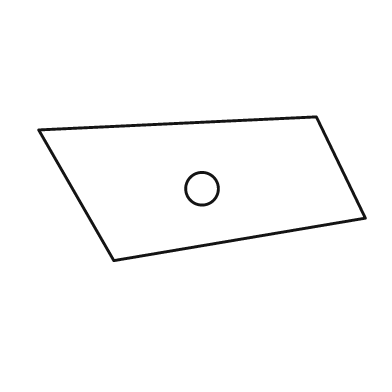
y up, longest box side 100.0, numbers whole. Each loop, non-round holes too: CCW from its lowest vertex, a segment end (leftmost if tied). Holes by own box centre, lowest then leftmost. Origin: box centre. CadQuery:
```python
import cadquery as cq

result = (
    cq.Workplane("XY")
    .moveTo(-27.0, -22.0)
    .lineTo(50.0, -9.0)
    .lineTo(35.0, 22.0)
    .lineTo(-50.0, 18.0)
    .close()
    .moveTo(0.0, 0.0)
    .circle(5.0)
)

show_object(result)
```